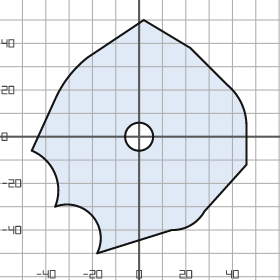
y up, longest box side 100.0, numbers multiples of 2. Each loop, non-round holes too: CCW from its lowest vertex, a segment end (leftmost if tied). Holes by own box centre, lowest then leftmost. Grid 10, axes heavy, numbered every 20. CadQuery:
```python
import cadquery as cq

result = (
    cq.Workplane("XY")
    .moveTo(-18.0, -50.0)
    .lineTo(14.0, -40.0)
    .threePointArc((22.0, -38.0), (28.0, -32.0))
    .lineTo(46.0, -12.0)
    .lineTo(46.0, 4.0)
    .threePointArc((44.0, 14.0), (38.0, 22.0))
    .lineTo(22.0, 38.0)
    .lineTo(2.0, 50.0)
    .lineTo(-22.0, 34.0)
    .threePointArc((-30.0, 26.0), (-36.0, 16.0))
    .lineTo(-46.0, -6.0)
    .threePointArc((-36.0, -16.0), (-36.0, -30.0))
    .threePointArc((-20.0, -34.0), (-18.0, -50.0))
    .close()
    .moveTo(0.0, 0.0)
    .circle(6.0)
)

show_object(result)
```